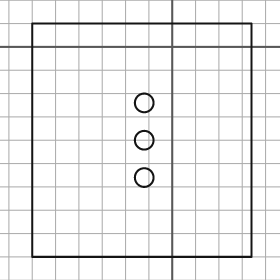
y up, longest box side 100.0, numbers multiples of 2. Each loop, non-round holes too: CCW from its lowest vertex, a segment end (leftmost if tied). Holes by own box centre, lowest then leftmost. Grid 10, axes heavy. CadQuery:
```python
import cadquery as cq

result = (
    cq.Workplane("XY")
    .moveTo(-60.0, -90.0)
    .lineTo(34.0, -90.0)
    .lineTo(34.0, 10.0)
    .lineTo(-60.0, 10.0)
    .close()
    .moveTo(-12.0, -56.0)
    .circle(4.0)
    .moveTo(-12.0, -40.0)
    .circle(4.0)
    .moveTo(-12.0, -24.0)
    .circle(4.0)
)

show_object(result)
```